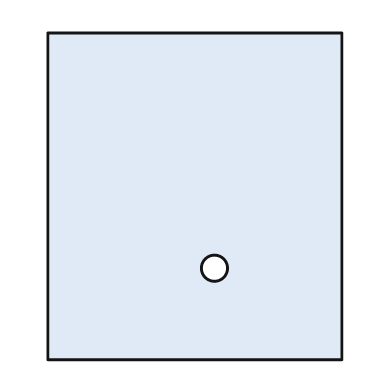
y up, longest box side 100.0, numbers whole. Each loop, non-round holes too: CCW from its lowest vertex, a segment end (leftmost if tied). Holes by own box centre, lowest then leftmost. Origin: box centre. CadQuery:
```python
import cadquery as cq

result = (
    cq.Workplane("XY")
    .moveTo(-45.0, -50.0)
    .lineTo(45.0, -50.0)
    .lineTo(45.0, 50.0)
    .lineTo(-45.0, 50.0)
    .close()
    .moveTo(6.0, -22.0)
    .circle(4.0)
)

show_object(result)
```